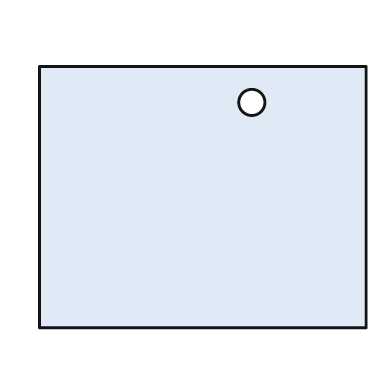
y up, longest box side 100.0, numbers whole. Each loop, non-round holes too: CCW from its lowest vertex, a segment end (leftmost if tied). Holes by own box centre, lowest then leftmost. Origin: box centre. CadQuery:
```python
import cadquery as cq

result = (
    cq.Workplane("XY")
    .moveTo(-50.0, -40.0)
    .lineTo(50.0, -40.0)
    .lineTo(50.0, 40.0)
    .lineTo(-50.0, 40.0)
    .close()
    .moveTo(15.0, 29.0)
    .circle(4.0)
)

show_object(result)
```